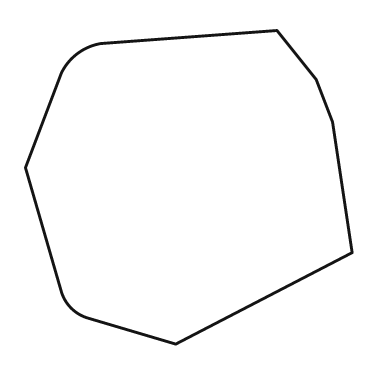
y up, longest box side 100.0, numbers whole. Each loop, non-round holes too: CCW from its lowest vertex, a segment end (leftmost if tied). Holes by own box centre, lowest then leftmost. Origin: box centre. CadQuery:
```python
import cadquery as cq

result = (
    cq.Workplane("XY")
    .moveTo(-4.0, -48.0)
    .lineTo(50.0, -20.0)
    .lineTo(44.0, 20.0)
    .lineTo(39.0, 33.0)
    .lineTo(27.0, 48.0)
    .lineTo(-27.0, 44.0)
    .threePointArc((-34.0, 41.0), (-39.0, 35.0))
    .lineTo(-50.0, 6.0)
    .lineTo(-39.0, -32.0)
    .threePointArc((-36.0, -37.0), (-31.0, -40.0))
    .close()
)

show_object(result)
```